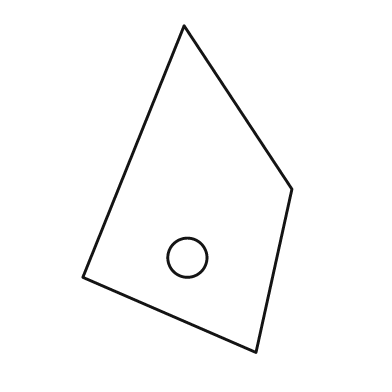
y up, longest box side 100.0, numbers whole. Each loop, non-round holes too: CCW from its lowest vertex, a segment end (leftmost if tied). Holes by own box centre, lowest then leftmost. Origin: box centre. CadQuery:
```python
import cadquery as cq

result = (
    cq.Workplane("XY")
    .moveTo(21.0, -50.0)
    .lineTo(32.0, 0.0)
    .lineTo(-1.0, 50.0)
    .lineTo(-32.0, -27.0)
    .close()
    .moveTo(0.0, -21.0)
    .circle(6.0)
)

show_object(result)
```